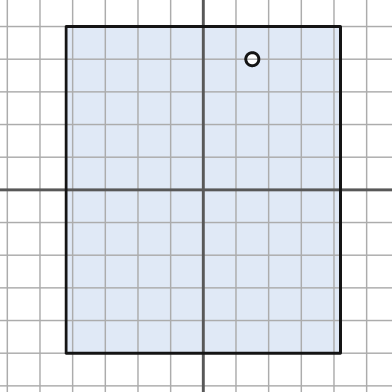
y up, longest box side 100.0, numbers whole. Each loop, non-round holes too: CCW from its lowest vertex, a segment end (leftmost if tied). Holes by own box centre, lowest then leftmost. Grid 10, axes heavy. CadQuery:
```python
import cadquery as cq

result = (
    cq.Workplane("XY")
    .moveTo(-42.0, -50.0)
    .lineTo(42.0, -50.0)
    .lineTo(42.0, 50.0)
    .lineTo(-42.0, 50.0)
    .close()
    .moveTo(15.0, 40.0)
    .circle(2.0)
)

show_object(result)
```